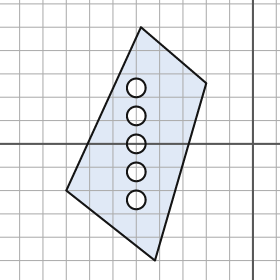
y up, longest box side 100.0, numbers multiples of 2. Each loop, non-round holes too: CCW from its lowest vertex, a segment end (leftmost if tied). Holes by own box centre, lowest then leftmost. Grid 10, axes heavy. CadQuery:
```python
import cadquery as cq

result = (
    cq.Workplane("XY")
    .moveTo(-42.0, -50.0)
    .lineTo(-20.0, 26.0)
    .lineTo(-48.0, 50.0)
    .lineTo(-80.0, -20.0)
    .close()
    .moveTo(-50.0, -24.0)
    .circle(4.0)
    .moveTo(-50.0, -12.0)
    .circle(4.0)
    .moveTo(-50.0, 0.0)
    .circle(4.0)
    .moveTo(-50.0, 12.0)
    .circle(4.0)
    .moveTo(-50.0, 24.0)
    .circle(4.0)
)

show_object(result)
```